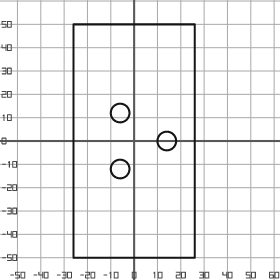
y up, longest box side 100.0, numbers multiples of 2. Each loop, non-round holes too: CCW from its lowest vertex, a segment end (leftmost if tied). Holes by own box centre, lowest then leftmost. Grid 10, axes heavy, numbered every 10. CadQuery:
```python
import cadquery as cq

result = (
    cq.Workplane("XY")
    .moveTo(-26.0, -50.0)
    .lineTo(26.0, -50.0)
    .lineTo(26.0, 50.0)
    .lineTo(-26.0, 50.0)
    .close()
    .moveTo(-6.0, -12.0)
    .circle(4.0)
    .moveTo(14.0, 0.0)
    .circle(4.0)
    .moveTo(-6.0, 12.0)
    .circle(4.0)
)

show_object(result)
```